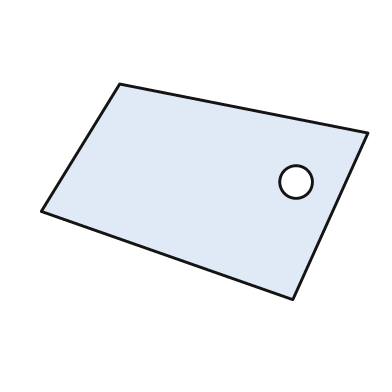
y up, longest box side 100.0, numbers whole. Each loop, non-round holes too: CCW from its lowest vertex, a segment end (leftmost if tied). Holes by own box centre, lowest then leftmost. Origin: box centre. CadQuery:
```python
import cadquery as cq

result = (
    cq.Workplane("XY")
    .moveTo(27.0, -33.0)
    .lineTo(50.0, 18.0)
    .lineTo(-26.0, 33.0)
    .lineTo(-50.0, -6.0)
    .close()
    .moveTo(28.0, 3.0)
    .circle(5.0)
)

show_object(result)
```